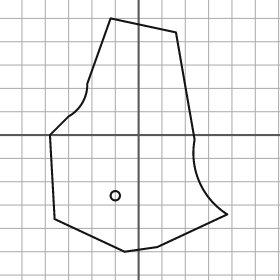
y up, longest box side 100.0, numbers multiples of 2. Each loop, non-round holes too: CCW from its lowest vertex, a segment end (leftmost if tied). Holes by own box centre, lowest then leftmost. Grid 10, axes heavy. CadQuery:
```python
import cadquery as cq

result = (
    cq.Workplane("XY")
    .moveTo(-6.0, -50.0)
    .lineTo(8.0, -48.0)
    .lineTo(38.0, -34.0)
    .threePointArc((26.0, -20.0), (24.0, -2.0))
    .lineTo(16.0, 44.0)
    .lineTo(-12.0, 50.0)
    .lineTo(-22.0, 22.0)
    .threePointArc((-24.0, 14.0), (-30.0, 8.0))
    .lineTo(-38.0, 0.0)
    .lineTo(-36.0, -36.0)
    .close()
    .moveTo(-10.0, -26.0)
    .circle(2.0)
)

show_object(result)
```